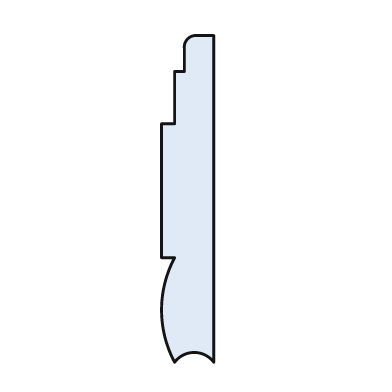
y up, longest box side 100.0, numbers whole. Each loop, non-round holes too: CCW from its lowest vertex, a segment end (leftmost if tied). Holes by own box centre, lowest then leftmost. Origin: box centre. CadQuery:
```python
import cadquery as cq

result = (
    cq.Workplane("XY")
    .moveTo(-4.0, -50.0)
    .threePointArc((2.0, -47.0), (8.0, -50.0))
    .lineTo(8.0, 50.0)
    .lineTo(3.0, 50.0)
    .threePointArc((0.0, 49.0), (-1.0, 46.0))
    .lineTo(-1.0, 39.0)
    .lineTo(-4.0, 39.0)
    .lineTo(-4.0, 23.0)
    .lineTo(-8.0, 23.0)
    .lineTo(-8.0, -18.0)
    .lineTo(-4.0, -18.0)
    .threePointArc((-8.0, -34.0), (-4.0, -50.0))
    .close()
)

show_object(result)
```